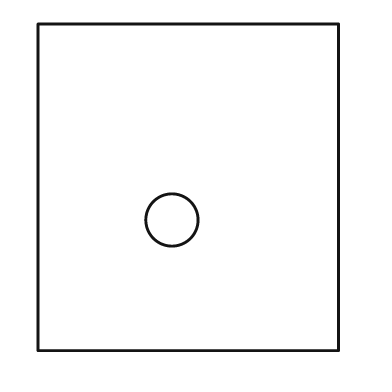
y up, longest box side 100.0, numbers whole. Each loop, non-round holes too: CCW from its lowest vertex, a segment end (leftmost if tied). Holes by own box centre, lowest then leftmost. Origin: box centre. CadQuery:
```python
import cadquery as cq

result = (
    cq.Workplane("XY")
    .moveTo(-46.0, -50.0)
    .lineTo(46.0, -50.0)
    .lineTo(46.0, 50.0)
    .lineTo(-46.0, 50.0)
    .close()
    .moveTo(-5.0, -10.0)
    .circle(8.0)
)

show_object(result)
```